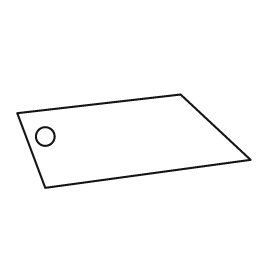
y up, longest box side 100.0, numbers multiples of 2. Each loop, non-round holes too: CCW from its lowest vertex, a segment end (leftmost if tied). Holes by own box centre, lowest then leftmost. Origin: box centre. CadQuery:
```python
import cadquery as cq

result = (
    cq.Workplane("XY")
    .moveTo(-38.0, -20.0)
    .lineTo(50.0, -8.0)
    .lineTo(20.0, 20.0)
    .lineTo(-50.0, 12.0)
    .close()
    .moveTo(-38.0, 2.0)
    .circle(4.0)
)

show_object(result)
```